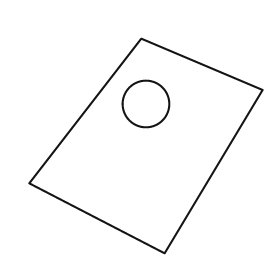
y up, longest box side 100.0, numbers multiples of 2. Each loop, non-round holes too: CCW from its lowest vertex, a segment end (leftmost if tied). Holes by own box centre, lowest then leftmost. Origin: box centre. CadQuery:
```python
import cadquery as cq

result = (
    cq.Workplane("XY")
    .moveTo(8.0, -46.0)
    .lineTo(50.0, 24.0)
    .lineTo(-2.0, 46.0)
    .lineTo(-50.0, -16.0)
    .close()
    .moveTo(0.0, 18.0)
    .circle(10.0)
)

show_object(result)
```